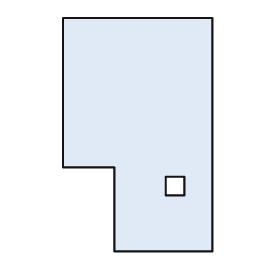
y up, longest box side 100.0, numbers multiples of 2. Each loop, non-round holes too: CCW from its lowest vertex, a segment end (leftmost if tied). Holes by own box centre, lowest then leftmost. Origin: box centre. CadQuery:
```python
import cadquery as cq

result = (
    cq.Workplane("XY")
    .moveTo(-10.0, -50.0)
    .lineTo(32.0, -50.0)
    .lineTo(32.0, 50.0)
    .lineTo(-32.0, 50.0)
    .lineTo(-32.0, -14.0)
    .lineTo(-10.0, -14.0)
    .close()
    .moveTo(12.0, -26.0)
    .lineTo(20.0, -26.0)
    .lineTo(20.0, -18.0)
    .lineTo(12.0, -18.0)
    .close()
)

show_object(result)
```